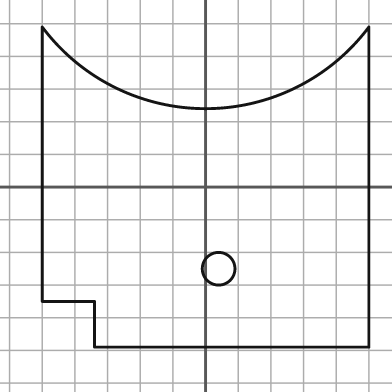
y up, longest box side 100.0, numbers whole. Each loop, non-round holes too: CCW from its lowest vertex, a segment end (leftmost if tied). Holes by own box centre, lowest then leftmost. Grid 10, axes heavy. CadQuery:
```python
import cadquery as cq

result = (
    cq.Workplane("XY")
    .moveTo(-34.0, -49.0)
    .lineTo(50.0, -49.0)
    .lineTo(50.0, 49.0)
    .threePointArc((0.0, 24.0), (-50.0, 49.0))
    .lineTo(-50.0, -35.0)
    .lineTo(-34.0, -35.0)
    .close()
    .moveTo(4.0, -25.0)
    .circle(5.0)
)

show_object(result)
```